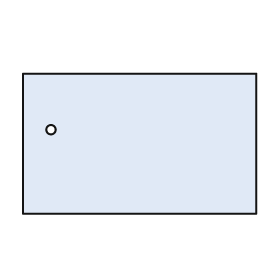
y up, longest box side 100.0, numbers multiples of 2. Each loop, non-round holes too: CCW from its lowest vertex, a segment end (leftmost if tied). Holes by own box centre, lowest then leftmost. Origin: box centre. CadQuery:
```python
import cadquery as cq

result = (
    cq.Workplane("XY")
    .moveTo(-50.0, -30.0)
    .lineTo(50.0, -30.0)
    .lineTo(50.0, 30.0)
    .lineTo(-50.0, 30.0)
    .close()
    .moveTo(-38.0, 6.0)
    .circle(2.0)
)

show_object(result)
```